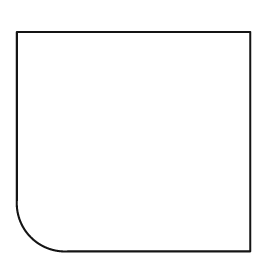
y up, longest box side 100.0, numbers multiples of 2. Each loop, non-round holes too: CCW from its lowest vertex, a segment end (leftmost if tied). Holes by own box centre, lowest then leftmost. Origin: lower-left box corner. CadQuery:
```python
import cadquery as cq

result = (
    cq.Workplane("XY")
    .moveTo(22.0, 0.0)
    .lineTo(100.0, 0.0)
    .lineTo(100.0, 94.0)
    .lineTo(0.0, 94.0)
    .lineTo(0.0, 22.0)
    .threePointArc((6.0, 6.0), (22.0, 0.0))
    .close()
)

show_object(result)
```